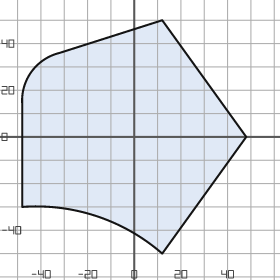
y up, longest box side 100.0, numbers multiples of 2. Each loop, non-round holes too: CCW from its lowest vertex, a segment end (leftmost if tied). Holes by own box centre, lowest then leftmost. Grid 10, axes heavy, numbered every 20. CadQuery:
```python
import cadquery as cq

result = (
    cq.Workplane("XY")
    .moveTo(12.0, -50.0)
    .lineTo(48.0, 0.0)
    .lineTo(12.0, 50.0)
    .lineTo(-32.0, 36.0)
    .threePointArc((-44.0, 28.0), (-48.0, 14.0))
    .lineTo(-48.0, -30.0)
    .threePointArc((-16.0, -34.0), (12.0, -50.0))
    .close()
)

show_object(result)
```